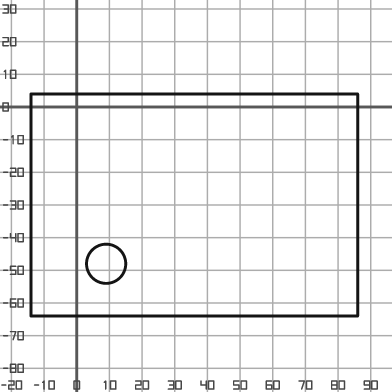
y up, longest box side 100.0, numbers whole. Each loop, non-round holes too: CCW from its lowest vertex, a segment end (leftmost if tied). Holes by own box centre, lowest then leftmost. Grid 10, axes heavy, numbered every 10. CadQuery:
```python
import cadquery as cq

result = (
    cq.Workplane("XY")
    .moveTo(-14.0, -64.0)
    .lineTo(86.0, -64.0)
    .lineTo(86.0, 4.0)
    .lineTo(-14.0, 4.0)
    .close()
    .moveTo(9.0, -48.0)
    .circle(6.0)
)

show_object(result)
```